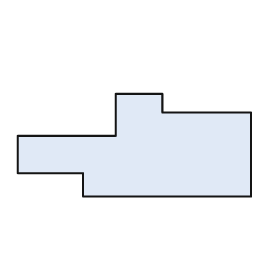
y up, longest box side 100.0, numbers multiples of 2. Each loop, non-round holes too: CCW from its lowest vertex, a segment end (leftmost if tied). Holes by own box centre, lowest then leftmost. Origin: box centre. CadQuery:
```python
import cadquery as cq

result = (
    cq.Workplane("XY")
    .moveTo(-22.0, -22.0)
    .lineTo(50.0, -22.0)
    .lineTo(50.0, 14.0)
    .lineTo(12.0, 14.0)
    .lineTo(12.0, 22.0)
    .lineTo(-8.0, 22.0)
    .lineTo(-8.0, 4.0)
    .lineTo(-50.0, 4.0)
    .lineTo(-50.0, -12.0)
    .lineTo(-22.0, -12.0)
    .close()
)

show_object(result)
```